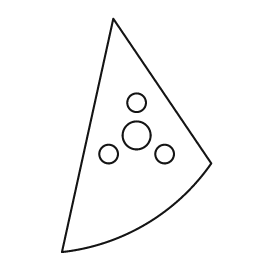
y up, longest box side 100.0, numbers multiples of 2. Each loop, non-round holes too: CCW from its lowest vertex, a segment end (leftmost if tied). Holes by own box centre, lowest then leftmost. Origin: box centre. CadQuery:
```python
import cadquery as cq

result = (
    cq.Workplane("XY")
    .moveTo(-32.0, -50.0)
    .threePointArc((4.0, -38.0), (32.0, -12.0))
    .lineTo(-10.0, 50.0)
    .close()
    .moveTo(-12.0, -8.0)
    .circle(4.0)
    .moveTo(12.0, -8.0)
    .circle(4.0)
    .moveTo(0.0, 0.0)
    .circle(6.0)
    .moveTo(0.0, 14.0)
    .circle(4.0)
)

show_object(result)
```